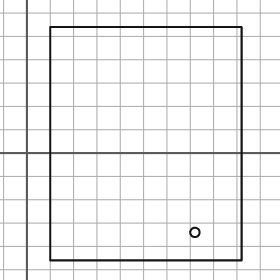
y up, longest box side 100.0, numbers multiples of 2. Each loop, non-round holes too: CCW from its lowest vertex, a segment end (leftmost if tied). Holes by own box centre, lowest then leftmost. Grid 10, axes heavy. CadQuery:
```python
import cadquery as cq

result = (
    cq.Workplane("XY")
    .moveTo(10.0, -46.0)
    .lineTo(92.0, -46.0)
    .lineTo(92.0, 54.0)
    .lineTo(10.0, 54.0)
    .close()
    .moveTo(72.0, -34.0)
    .circle(2.0)
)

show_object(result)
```